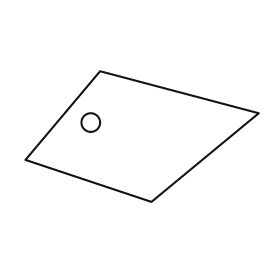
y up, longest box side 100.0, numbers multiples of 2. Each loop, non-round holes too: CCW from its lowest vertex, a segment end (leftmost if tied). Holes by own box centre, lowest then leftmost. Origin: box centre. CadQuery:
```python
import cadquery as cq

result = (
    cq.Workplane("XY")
    .moveTo(4.0, -28.0)
    .lineTo(50.0, 10.0)
    .lineTo(-18.0, 28.0)
    .lineTo(-50.0, -10.0)
    .close()
    .moveTo(-22.0, 6.0)
    .circle(4.0)
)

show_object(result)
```